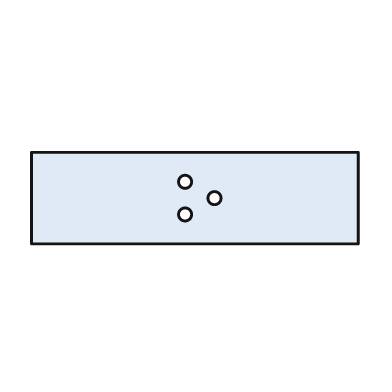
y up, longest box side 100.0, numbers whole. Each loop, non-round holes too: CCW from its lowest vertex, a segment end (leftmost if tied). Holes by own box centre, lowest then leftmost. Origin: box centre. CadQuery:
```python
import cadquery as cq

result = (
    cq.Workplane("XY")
    .moveTo(-50.0, -14.0)
    .lineTo(50.0, -14.0)
    .lineTo(50.0, 14.0)
    .lineTo(-50.0, 14.0)
    .close()
    .moveTo(-3.0, -5.0)
    .circle(2.0)
    .moveTo(6.0, 0.0)
    .circle(2.0)
    .moveTo(-3.0, 5.0)
    .circle(2.0)
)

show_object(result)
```